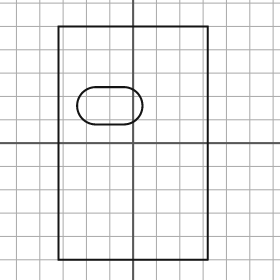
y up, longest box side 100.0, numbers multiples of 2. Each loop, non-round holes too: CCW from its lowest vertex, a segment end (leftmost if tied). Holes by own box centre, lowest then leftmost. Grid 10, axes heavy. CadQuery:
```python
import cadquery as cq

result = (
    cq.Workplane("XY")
    .moveTo(-32.0, -50.0)
    .lineTo(32.0, -50.0)
    .lineTo(32.0, 50.0)
    .lineTo(-32.0, 50.0)
    .close()
    .moveTo(-16.0, 8.0)
    .lineTo(-4.0, 8.0)
    .threePointArc((4.0, 16.0), (-4.0, 24.0))
    .lineTo(-16.0, 24.0)
    .threePointArc((-24.0, 16.0), (-16.0, 8.0))
    .close()
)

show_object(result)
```